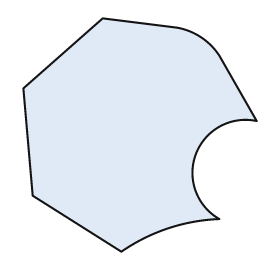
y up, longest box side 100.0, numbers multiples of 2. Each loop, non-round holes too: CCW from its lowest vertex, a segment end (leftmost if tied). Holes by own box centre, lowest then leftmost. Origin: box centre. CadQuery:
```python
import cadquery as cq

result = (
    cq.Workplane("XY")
    .moveTo(-8.0, -50.0)
    .threePointArc((12.0, -40.0), (34.0, -36.0))
    .threePointArc((24.0, -8.0), (50.0, 6.0))
    .lineTo(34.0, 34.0)
    .threePointArc((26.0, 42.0), (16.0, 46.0))
    .lineTo(-16.0, 50.0)
    .lineTo(-50.0, 20.0)
    .lineTo(-46.0, -26.0)
    .close()
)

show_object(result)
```